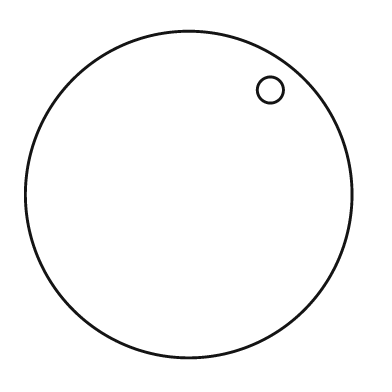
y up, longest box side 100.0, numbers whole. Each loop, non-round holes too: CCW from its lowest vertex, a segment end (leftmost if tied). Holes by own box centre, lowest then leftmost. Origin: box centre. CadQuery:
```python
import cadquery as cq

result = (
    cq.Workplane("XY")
    .moveTo(0.0, 0.0)
    .circle(50.0)
    .moveTo(25.0, 32.0)
    .circle(4.0)
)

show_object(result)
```